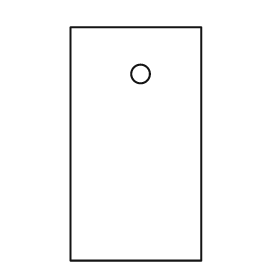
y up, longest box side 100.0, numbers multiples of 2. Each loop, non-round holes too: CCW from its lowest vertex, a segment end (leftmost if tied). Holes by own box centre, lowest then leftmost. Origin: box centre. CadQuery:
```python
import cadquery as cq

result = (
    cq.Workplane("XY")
    .moveTo(-28.0, -50.0)
    .lineTo(28.0, -50.0)
    .lineTo(28.0, 50.0)
    .lineTo(-28.0, 50.0)
    .close()
    .moveTo(2.0, 30.0)
    .circle(4.0)
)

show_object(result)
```